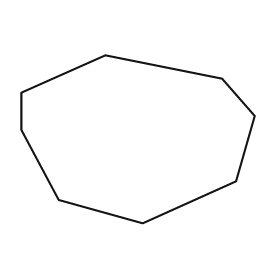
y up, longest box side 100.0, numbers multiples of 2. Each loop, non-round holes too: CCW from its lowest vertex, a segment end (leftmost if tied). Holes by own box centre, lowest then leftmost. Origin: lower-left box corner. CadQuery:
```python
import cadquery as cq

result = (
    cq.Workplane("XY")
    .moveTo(52.0, 0.0)
    .lineTo(92.0, 18.0)
    .lineTo(100.0, 46.0)
    .lineTo(86.0, 62.0)
    .lineTo(36.0, 72.0)
    .lineTo(0.0, 56.0)
    .lineTo(0.0, 40.0)
    .lineTo(16.0, 10.0)
    .close()
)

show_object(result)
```